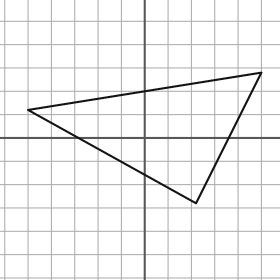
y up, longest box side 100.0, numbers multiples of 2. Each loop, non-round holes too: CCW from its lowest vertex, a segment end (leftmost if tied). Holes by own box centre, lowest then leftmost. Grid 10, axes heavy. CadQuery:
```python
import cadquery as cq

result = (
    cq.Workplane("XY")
    .moveTo(22.0, -28.0)
    .lineTo(50.0, 28.0)
    .lineTo(-50.0, 12.0)
    .close()
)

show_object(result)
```